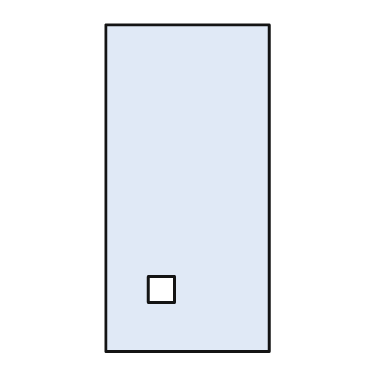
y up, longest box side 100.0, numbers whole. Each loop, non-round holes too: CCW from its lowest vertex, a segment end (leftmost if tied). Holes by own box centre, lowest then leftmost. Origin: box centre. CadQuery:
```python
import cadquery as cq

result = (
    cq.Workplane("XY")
    .moveTo(-25.0, -50.0)
    .lineTo(25.0, -50.0)
    .lineTo(25.0, 50.0)
    .lineTo(-25.0, 50.0)
    .close()
    .moveTo(-12.0, -35.0)
    .lineTo(-4.0, -35.0)
    .lineTo(-4.0, -27.0)
    .lineTo(-12.0, -27.0)
    .close()
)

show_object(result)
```